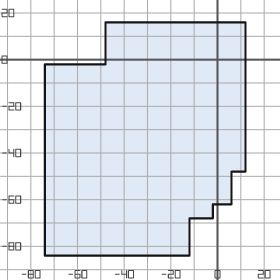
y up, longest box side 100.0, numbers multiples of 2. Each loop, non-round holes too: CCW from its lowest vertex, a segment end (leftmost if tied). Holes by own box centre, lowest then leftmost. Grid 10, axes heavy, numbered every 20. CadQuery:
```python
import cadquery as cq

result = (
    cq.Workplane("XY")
    .moveTo(-74.0, -84.0)
    .lineTo(-12.0, -84.0)
    .lineTo(-12.0, -68.0)
    .lineTo(-2.0, -68.0)
    .lineTo(-2.0, -62.0)
    .lineTo(6.0, -62.0)
    .lineTo(6.0, -48.0)
    .lineTo(12.0, -48.0)
    .lineTo(12.0, 16.0)
    .lineTo(-48.0, 16.0)
    .lineTo(-48.0, -2.0)
    .lineTo(-74.0, -2.0)
    .close()
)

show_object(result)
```